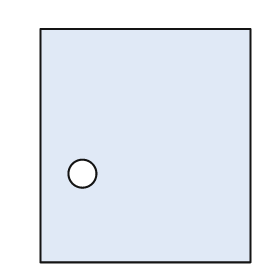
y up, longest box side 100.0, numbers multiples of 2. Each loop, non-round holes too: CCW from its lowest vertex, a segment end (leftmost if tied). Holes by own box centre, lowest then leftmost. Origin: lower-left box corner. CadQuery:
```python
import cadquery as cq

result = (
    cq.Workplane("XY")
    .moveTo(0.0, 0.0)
    .lineTo(90.0, 0.0)
    .lineTo(90.0, 100.0)
    .lineTo(0.0, 100.0)
    .close()
    .moveTo(18.0, 38.0)
    .circle(6.0)
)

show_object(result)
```